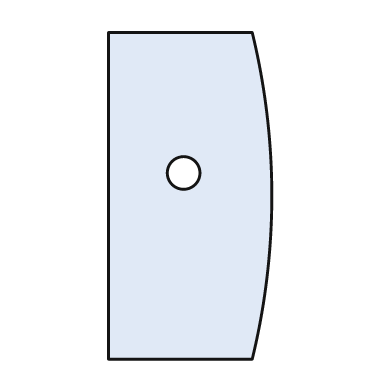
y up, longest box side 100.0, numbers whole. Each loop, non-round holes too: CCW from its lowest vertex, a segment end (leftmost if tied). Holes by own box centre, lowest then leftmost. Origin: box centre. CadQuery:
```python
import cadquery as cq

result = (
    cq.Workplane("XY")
    .moveTo(-25.0, -50.0)
    .lineTo(19.0, -50.0)
    .threePointArc((25.0, 0.0), (19.0, 50.0))
    .lineTo(-25.0, 50.0)
    .close()
    .moveTo(-2.0, 7.0)
    .circle(5.0)
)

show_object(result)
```